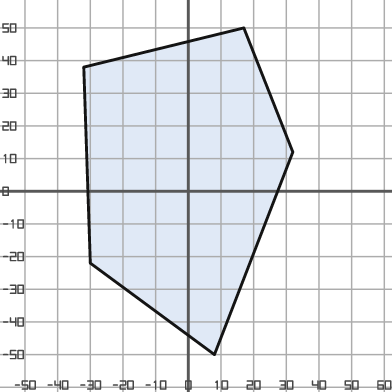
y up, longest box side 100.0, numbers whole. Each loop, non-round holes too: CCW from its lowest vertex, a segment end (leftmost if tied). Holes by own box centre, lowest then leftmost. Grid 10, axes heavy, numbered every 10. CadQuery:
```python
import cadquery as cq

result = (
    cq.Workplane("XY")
    .moveTo(8.0, -50.0)
    .lineTo(32.0, 12.0)
    .lineTo(17.0, 50.0)
    .lineTo(-32.0, 38.0)
    .lineTo(-30.0, -22.0)
    .close()
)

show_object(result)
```